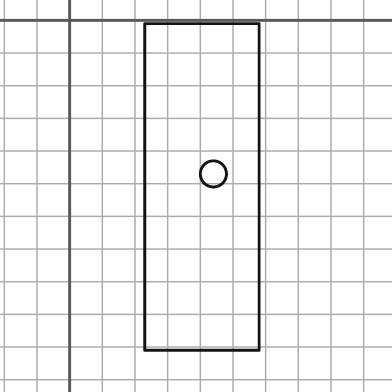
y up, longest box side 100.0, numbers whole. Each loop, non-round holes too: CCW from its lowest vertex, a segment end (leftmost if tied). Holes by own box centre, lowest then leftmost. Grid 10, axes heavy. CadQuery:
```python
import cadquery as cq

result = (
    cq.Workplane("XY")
    .moveTo(23.0, -101.0)
    .lineTo(58.0, -101.0)
    .lineTo(58.0, -1.0)
    .lineTo(23.0, -1.0)
    .close()
    .moveTo(44.0, -47.0)
    .circle(4.0)
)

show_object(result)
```